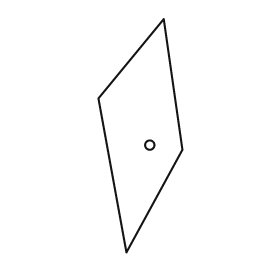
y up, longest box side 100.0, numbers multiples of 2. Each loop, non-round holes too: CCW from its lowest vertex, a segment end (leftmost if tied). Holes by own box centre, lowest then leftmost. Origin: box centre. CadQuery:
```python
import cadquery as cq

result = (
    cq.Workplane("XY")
    .moveTo(-6.0, -50.0)
    .lineTo(18.0, -6.0)
    .lineTo(10.0, 50.0)
    .lineTo(-18.0, 16.0)
    .close()
    .moveTo(4.0, -4.0)
    .circle(2.0)
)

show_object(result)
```